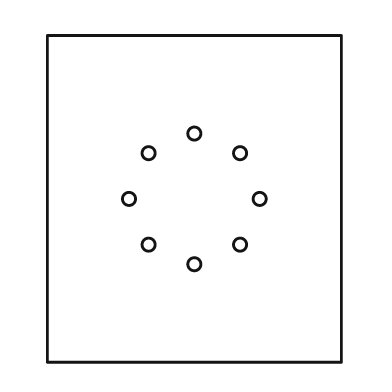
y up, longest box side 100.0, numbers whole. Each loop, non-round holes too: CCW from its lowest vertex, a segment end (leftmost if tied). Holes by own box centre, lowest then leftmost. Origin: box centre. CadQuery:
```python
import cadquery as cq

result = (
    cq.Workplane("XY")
    .moveTo(-45.0, -50.0)
    .lineTo(45.0, -50.0)
    .lineTo(45.0, 50.0)
    .lineTo(-45.0, 50.0)
    .close()
    .moveTo(0.0, -20.0)
    .circle(2.0)
    .moveTo(-14.0, -14.0)
    .circle(2.0)
    .moveTo(14.0, -14.0)
    .circle(2.0)
    .moveTo(-20.0, 0.0)
    .circle(2.0)
    .moveTo(20.0, 0.0)
    .circle(2.0)
    .moveTo(-14.0, 14.0)
    .circle(2.0)
    .moveTo(14.0, 14.0)
    .circle(2.0)
    .moveTo(0.0, 20.0)
    .circle(2.0)
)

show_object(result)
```